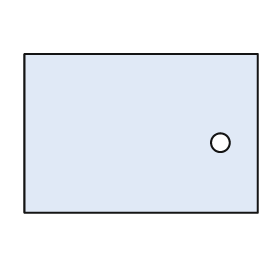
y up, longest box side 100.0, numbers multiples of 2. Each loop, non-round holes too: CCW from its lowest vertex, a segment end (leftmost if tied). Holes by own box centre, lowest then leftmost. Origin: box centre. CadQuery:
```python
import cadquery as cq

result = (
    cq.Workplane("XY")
    .moveTo(-50.0, -34.0)
    .lineTo(50.0, -34.0)
    .lineTo(50.0, 34.0)
    .lineTo(-50.0, 34.0)
    .close()
    .moveTo(34.0, -4.0)
    .circle(4.0)
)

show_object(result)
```